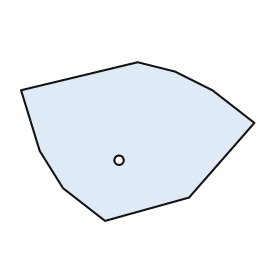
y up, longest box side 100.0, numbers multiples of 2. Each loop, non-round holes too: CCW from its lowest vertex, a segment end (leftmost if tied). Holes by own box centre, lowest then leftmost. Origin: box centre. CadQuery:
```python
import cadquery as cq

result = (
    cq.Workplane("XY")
    .moveTo(-14.0, -34.0)
    .lineTo(22.0, -24.0)
    .lineTo(50.0, 8.0)
    .lineTo(32.0, 22.0)
    .lineTo(16.0, 30.0)
    .lineTo(0.0, 34.0)
    .lineTo(-50.0, 22.0)
    .lineTo(-42.0, -4.0)
    .lineTo(-32.0, -20.0)
    .close()
    .moveTo(-8.0, -8.0)
    .circle(2.0)
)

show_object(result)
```